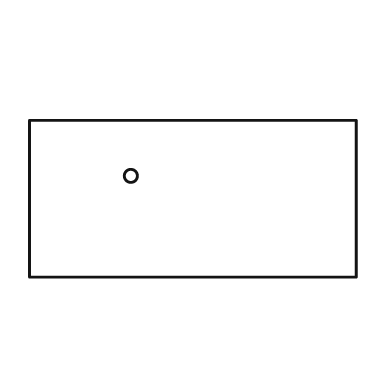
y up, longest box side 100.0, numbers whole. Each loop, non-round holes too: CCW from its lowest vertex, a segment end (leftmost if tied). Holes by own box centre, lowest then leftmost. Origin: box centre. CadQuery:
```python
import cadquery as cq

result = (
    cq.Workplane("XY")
    .moveTo(-50.0, -24.0)
    .lineTo(50.0, -24.0)
    .lineTo(50.0, 24.0)
    .lineTo(-50.0, 24.0)
    .close()
    .moveTo(-19.0, 7.0)
    .circle(2.0)
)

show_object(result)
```